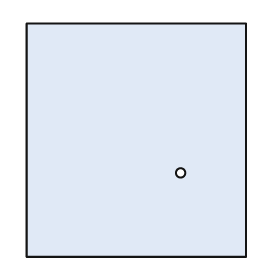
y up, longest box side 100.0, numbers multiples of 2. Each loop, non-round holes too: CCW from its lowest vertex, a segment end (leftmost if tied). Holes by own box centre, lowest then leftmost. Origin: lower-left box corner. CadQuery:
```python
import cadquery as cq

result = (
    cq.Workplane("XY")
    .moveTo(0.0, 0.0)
    .lineTo(94.0, 0.0)
    .lineTo(94.0, 100.0)
    .lineTo(0.0, 100.0)
    .close()
    .moveTo(66.0, 36.0)
    .circle(2.0)
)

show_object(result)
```